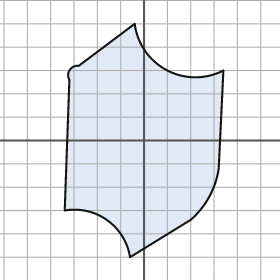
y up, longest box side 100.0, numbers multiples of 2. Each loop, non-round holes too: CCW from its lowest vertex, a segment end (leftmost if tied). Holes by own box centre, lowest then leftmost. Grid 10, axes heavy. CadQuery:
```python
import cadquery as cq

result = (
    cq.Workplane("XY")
    .moveTo(-6.0, -50.0)
    .lineTo(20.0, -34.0)
    .threePointArc((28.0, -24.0), (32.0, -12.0))
    .lineTo(34.0, 30.0)
    .threePointArc((10.0, 30.0), (-4.0, 50.0))
    .lineTo(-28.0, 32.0)
    .threePointArc((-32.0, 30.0), (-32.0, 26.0))
    .lineTo(-34.0, -30.0)
    .threePointArc((-16.0, -34.0), (-6.0, -50.0))
    .close()
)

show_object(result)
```